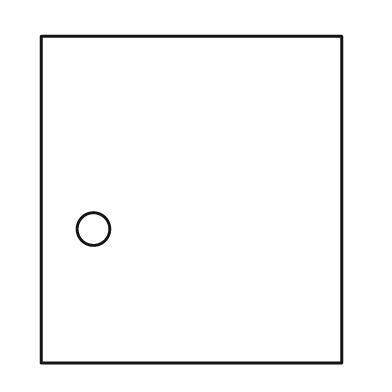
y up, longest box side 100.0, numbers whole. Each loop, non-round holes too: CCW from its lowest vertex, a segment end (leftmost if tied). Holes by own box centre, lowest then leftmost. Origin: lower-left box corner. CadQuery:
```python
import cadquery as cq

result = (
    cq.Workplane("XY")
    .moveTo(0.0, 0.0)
    .lineTo(92.0, 0.0)
    .lineTo(92.0, 100.0)
    .lineTo(0.0, 100.0)
    .close()
    .moveTo(16.0, 41.0)
    .circle(5.0)
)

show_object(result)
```